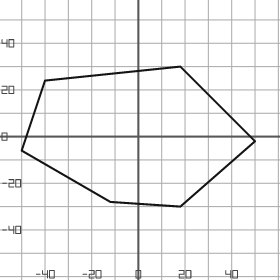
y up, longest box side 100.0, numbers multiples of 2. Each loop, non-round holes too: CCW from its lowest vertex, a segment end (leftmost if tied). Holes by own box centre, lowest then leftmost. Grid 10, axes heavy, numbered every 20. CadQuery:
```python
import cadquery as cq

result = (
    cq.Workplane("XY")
    .moveTo(18.0, -30.0)
    .lineTo(50.0, -2.0)
    .lineTo(18.0, 30.0)
    .lineTo(-40.0, 24.0)
    .lineTo(-50.0, -6.0)
    .lineTo(-12.0, -28.0)
    .close()
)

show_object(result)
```